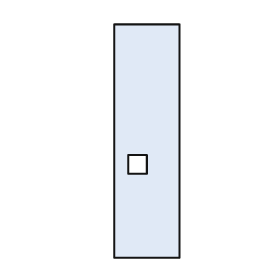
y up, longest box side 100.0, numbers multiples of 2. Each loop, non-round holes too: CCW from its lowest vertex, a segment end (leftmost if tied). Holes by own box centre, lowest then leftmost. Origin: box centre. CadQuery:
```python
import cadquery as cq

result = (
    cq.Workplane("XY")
    .moveTo(-14.0, -50.0)
    .lineTo(14.0, -50.0)
    .lineTo(14.0, 50.0)
    .lineTo(-14.0, 50.0)
    .close()
    .moveTo(-8.0, -14.0)
    .lineTo(0.0, -14.0)
    .lineTo(0.0, -6.0)
    .lineTo(-8.0, -6.0)
    .close()
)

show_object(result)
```